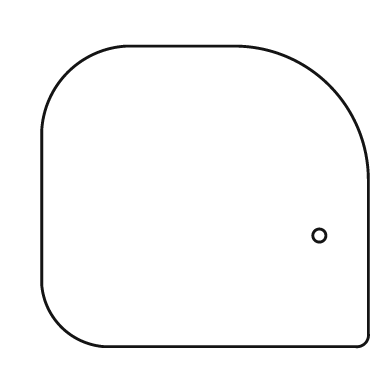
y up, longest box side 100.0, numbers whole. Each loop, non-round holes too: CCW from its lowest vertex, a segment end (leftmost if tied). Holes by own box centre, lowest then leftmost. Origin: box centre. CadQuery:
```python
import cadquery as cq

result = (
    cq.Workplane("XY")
    .moveTo(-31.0, -46.0)
    .lineTo(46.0, -46.0)
    .threePointArc((49.0, -45.0), (50.0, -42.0))
    .lineTo(50.0, 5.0)
    .threePointArc((38.0, 34.0), (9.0, 46.0))
    .lineTo(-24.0, 46.0)
    .threePointArc((-42.0, 38.0), (-50.0, 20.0))
    .lineTo(-50.0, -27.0)
    .threePointArc((-44.0, -40.0), (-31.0, -46.0))
    .close()
    .moveTo(35.0, -12.0)
    .circle(2.0)
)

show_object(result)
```